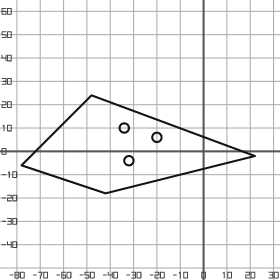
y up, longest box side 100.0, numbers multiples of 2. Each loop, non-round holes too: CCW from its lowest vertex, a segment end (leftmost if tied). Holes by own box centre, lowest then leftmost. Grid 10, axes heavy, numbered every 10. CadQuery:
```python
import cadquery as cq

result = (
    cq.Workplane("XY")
    .moveTo(-42.0, -18.0)
    .lineTo(22.0, -2.0)
    .lineTo(-48.0, 24.0)
    .lineTo(-78.0, -6.0)
    .close()
    .moveTo(-32.0, -4.0)
    .circle(2.0)
    .moveTo(-20.0, 6.0)
    .circle(2.0)
    .moveTo(-34.0, 10.0)
    .circle(2.0)
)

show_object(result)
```